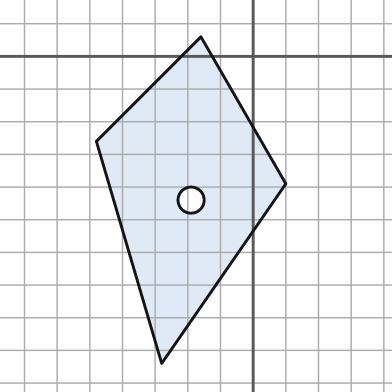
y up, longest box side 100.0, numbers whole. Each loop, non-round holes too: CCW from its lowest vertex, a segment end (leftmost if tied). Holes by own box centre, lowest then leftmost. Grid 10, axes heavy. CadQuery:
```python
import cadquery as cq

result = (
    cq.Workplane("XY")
    .moveTo(-28.0, -94.0)
    .lineTo(10.0, -39.0)
    .lineTo(-16.0, 6.0)
    .lineTo(-48.0, -26.0)
    .close()
    .moveTo(-19.0, -44.0)
    .circle(4.0)
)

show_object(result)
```